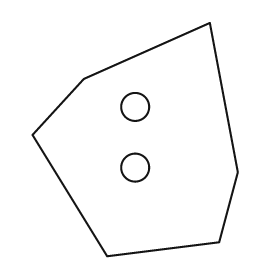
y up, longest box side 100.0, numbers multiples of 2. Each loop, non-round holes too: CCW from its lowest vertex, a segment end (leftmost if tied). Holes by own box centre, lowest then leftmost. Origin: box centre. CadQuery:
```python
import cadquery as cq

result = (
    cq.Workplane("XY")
    .moveTo(-12.0, -50.0)
    .lineTo(36.0, -44.0)
    .lineTo(44.0, -14.0)
    .lineTo(32.0, 50.0)
    .lineTo(-22.0, 26.0)
    .lineTo(-44.0, 2.0)
    .close()
    .moveTo(0.0, -12.0)
    .circle(6.0)
    .moveTo(0.0, 14.0)
    .circle(6.0)
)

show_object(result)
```